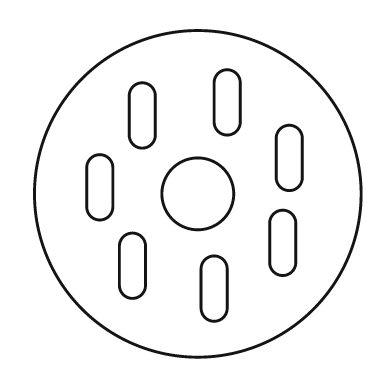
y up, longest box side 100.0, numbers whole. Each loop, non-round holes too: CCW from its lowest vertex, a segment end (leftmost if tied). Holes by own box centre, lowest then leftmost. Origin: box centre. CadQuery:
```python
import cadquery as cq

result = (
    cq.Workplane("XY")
    .moveTo(0.0, 0.0)
    .circle(50.0)
    .moveTo(1.0, -35.0)
    .threePointArc((5.0, -39.0), (9.0, -35.0))
    .lineTo(9.0, -23.0)
    .threePointArc((5.0, -19.0), (1.0, -23.0))
    .close()
    .moveTo(-24.0, -28.0)
    .threePointArc((-20.0, -32.0), (-16.0, -28.0))
    .lineTo(-16.0, -16.0)
    .threePointArc((-20.0, -12.0), (-24.0, -16.0))
    .close()
    .moveTo(22.0, -21.0)
    .threePointArc((26.0, -25.0), (30.0, -21.0))
    .lineTo(30.0, -9.0)
    .threePointArc((26.0, -5.0), (22.0, -9.0))
    .close()
    .moveTo(0.0, 0.0)
    .circle(11.0)
    .moveTo(-34.0, -4.0)
    .threePointArc((-30.0, -8.0), (-26.0, -4.0))
    .lineTo(-26.0, 8.0)
    .threePointArc((-30.0, 12.0), (-34.0, 8.0))
    .close()
    .moveTo(24.0, 5.0)
    .threePointArc((28.0, 1.0), (32.0, 5.0))
    .lineTo(32.0, 17.0)
    .threePointArc((28.0, 21.0), (24.0, 17.0))
    .close()
    .moveTo(-21.0, 18.0)
    .threePointArc((-17.0, 14.0), (-13.0, 18.0))
    .lineTo(-13.0, 30.0)
    .threePointArc((-17.0, 34.0), (-21.0, 30.0))
    .close()
    .moveTo(5.0, 22.0)
    .threePointArc((9.0, 18.0), (13.0, 22.0))
    .lineTo(13.0, 34.0)
    .threePointArc((9.0, 38.0), (5.0, 34.0))
    .close()
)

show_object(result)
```